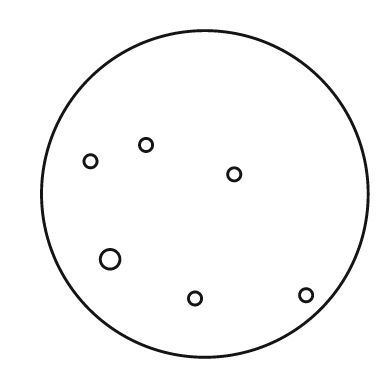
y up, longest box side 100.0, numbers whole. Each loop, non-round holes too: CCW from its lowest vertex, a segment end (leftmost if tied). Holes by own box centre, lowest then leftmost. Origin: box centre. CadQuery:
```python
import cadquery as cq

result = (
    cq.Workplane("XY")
    .moveTo(0.0, 0.0)
    .circle(50.0)
    .moveTo(-3.0, -32.0)
    .circle(2.0)
    .moveTo(31.0, -31.0)
    .circle(2.0)
    .moveTo(-29.0, -20.0)
    .circle(3.0)
    .moveTo(9.0, 6.0)
    .circle(2.0)
    .moveTo(-35.0, 10.0)
    .circle(2.0)
    .moveTo(-18.0, 15.0)
    .circle(2.0)
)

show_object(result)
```